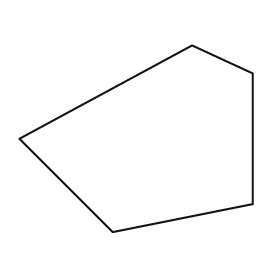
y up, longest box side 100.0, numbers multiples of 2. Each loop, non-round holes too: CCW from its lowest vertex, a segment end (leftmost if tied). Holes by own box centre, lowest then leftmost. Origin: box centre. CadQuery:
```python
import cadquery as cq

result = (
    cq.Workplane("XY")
    .moveTo(-10.0, -40.0)
    .lineTo(50.0, -28.0)
    .lineTo(50.0, 28.0)
    .lineTo(24.0, 40.0)
    .lineTo(-50.0, 0.0)
    .close()
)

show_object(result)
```